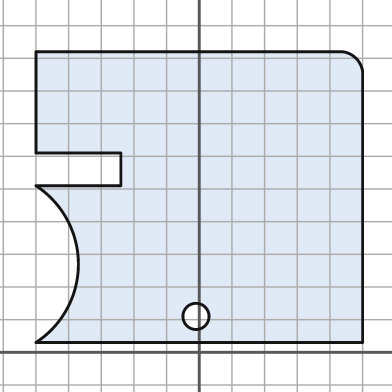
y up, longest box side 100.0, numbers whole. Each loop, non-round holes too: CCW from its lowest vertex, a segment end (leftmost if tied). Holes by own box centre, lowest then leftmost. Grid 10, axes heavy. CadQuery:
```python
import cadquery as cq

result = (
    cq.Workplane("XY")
    .moveTo(-50.0, 3.0)
    .lineTo(50.0, 3.0)
    .lineTo(50.0, 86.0)
    .threePointArc((48.0, 90.0), (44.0, 92.0))
    .lineTo(-50.0, 92.0)
    .lineTo(-50.0, 61.0)
    .lineTo(-24.0, 61.0)
    .lineTo(-24.0, 51.0)
    .lineTo(-50.0, 51.0)
    .threePointArc((-37.0, 27.0), (-50.0, 3.0))
    .close()
    .moveTo(-1.0, 11.0)
    .circle(4.0)
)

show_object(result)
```